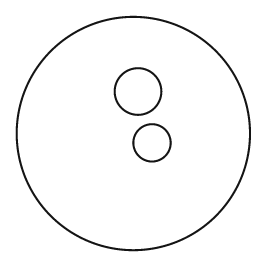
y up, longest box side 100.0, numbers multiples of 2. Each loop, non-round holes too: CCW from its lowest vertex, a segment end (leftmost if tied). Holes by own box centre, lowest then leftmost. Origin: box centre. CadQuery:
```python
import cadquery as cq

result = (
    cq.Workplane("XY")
    .moveTo(0.0, 0.0)
    .circle(50.0)
    .moveTo(8.0, -4.0)
    .circle(8.0)
    .moveTo(2.0, 18.0)
    .circle(10.0)
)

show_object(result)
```